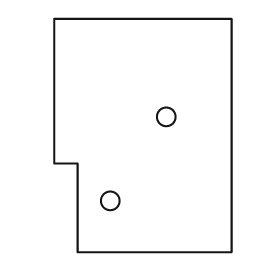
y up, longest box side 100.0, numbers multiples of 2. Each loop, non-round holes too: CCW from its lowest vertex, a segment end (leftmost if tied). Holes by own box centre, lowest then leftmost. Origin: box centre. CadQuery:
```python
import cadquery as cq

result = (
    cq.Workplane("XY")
    .moveTo(-28.0, -50.0)
    .lineTo(38.0, -50.0)
    .lineTo(38.0, 50.0)
    .lineTo(-38.0, 50.0)
    .lineTo(-38.0, -12.0)
    .lineTo(-28.0, -12.0)
    .close()
    .moveTo(-14.0, -28.0)
    .circle(4.0)
    .moveTo(10.0, 8.0)
    .circle(4.0)
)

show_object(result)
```